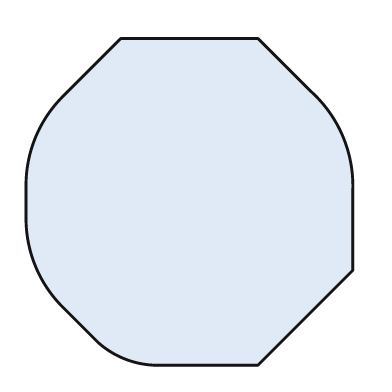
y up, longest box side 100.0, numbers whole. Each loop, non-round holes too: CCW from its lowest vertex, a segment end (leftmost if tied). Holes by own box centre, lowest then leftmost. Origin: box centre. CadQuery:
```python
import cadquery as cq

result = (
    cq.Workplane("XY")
    .moveTo(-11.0, -50.0)
    .lineTo(21.0, -50.0)
    .lineTo(50.0, -21.0)
    .lineTo(50.0, 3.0)
    .threePointArc((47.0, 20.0), (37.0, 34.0))
    .lineTo(21.0, 50.0)
    .lineTo(-21.0, 50.0)
    .lineTo(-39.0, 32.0)
    .threePointArc((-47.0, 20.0), (-50.0, 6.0))
    .lineTo(-50.0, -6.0)
    .threePointArc((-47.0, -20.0), (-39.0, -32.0))
    .lineTo(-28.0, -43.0)
    .threePointArc((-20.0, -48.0), (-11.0, -50.0))
    .close()
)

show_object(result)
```